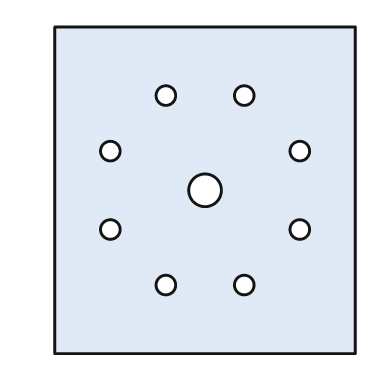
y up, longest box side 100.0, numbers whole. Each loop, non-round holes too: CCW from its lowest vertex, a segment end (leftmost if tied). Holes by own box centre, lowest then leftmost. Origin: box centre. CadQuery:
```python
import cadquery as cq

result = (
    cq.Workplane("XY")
    .moveTo(-46.0, -50.0)
    .lineTo(46.0, -50.0)
    .lineTo(46.0, 50.0)
    .lineTo(-46.0, 50.0)
    .close()
    .moveTo(-12.0, -29.0)
    .circle(3.0)
    .moveTo(12.0, -29.0)
    .circle(3.0)
    .moveTo(-29.0, -12.0)
    .circle(3.0)
    .moveTo(29.0, -12.0)
    .circle(3.0)
    .moveTo(0.0, 0.0)
    .circle(5.0)
    .moveTo(-29.0, 12.0)
    .circle(3.0)
    .moveTo(29.0, 12.0)
    .circle(3.0)
    .moveTo(-12.0, 29.0)
    .circle(3.0)
    .moveTo(12.0, 29.0)
    .circle(3.0)
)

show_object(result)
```